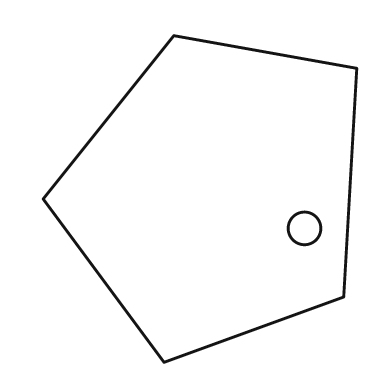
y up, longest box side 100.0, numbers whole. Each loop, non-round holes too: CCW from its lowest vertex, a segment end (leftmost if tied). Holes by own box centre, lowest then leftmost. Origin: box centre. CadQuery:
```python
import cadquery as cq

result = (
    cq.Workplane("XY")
    .moveTo(-11.0, -50.0)
    .lineTo(44.0, -30.0)
    .lineTo(48.0, 40.0)
    .lineTo(-8.0, 50.0)
    .lineTo(-48.0, 0.0)
    .close()
    .moveTo(32.0, -9.0)
    .circle(5.0)
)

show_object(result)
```